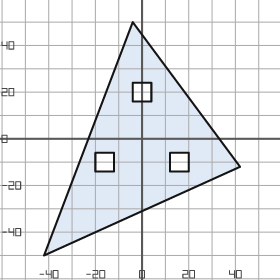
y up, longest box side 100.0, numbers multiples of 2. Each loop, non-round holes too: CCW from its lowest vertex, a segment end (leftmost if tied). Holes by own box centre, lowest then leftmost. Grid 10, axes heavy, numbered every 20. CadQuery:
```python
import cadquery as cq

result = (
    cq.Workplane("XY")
    .moveTo(-42.0, -50.0)
    .lineTo(42.0, -12.0)
    .lineTo(-4.0, 50.0)
    .close()
    .moveTo(-20.0, -14.0)
    .lineTo(-12.0, -14.0)
    .lineTo(-12.0, -6.0)
    .lineTo(-20.0, -6.0)
    .close()
    .moveTo(12.0, -14.0)
    .lineTo(20.0, -14.0)
    .lineTo(20.0, -6.0)
    .lineTo(12.0, -6.0)
    .close()
    .moveTo(-4.0, 16.0)
    .lineTo(4.0, 16.0)
    .lineTo(4.0, 24.0)
    .lineTo(-4.0, 24.0)
    .close()
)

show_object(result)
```